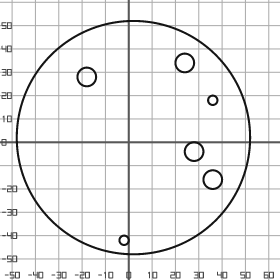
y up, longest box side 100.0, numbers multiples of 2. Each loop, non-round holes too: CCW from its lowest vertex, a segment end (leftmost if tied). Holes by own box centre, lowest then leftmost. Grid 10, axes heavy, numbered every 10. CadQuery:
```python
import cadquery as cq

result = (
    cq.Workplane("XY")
    .moveTo(2.0, 2.0)
    .circle(50.0)
    .moveTo(-2.0, -42.0)
    .circle(2.0)
    .moveTo(36.0, -16.0)
    .circle(4.0)
    .moveTo(28.0, -4.0)
    .circle(4.0)
    .moveTo(36.0, 18.0)
    .circle(2.0)
    .moveTo(-18.0, 28.0)
    .circle(4.0)
    .moveTo(24.0, 34.0)
    .circle(4.0)
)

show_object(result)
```